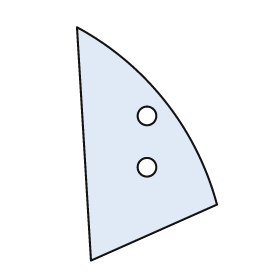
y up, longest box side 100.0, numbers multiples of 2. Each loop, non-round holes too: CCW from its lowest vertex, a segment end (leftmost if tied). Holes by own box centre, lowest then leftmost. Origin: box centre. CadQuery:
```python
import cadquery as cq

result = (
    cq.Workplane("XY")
    .moveTo(-24.0, -50.0)
    .lineTo(30.0, -26.0)
    .threePointArc((8.0, 18.0), (-30.0, 50.0))
    .close()
    .moveTo(0.0, -10.0)
    .circle(4.0)
    .moveTo(0.0, 12.0)
    .circle(4.0)
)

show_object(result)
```